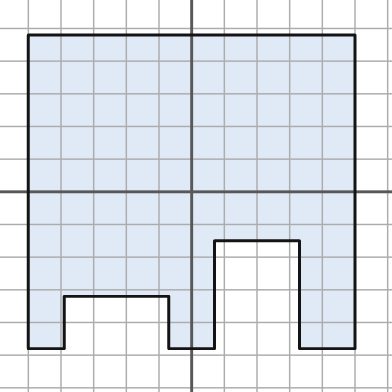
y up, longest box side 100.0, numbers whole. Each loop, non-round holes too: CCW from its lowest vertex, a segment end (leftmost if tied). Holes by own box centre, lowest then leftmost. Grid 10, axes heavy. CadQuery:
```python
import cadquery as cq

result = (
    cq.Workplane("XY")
    .moveTo(-50.0, -48.0)
    .lineTo(-39.0, -48.0)
    .lineTo(-39.0, -32.0)
    .lineTo(-7.0, -32.0)
    .lineTo(-7.0, -48.0)
    .lineTo(7.0, -48.0)
    .lineTo(7.0, -15.0)
    .lineTo(33.0, -15.0)
    .lineTo(33.0, -48.0)
    .lineTo(50.0, -48.0)
    .lineTo(50.0, 48.0)
    .lineTo(-50.0, 48.0)
    .close()
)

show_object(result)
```